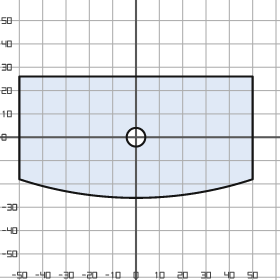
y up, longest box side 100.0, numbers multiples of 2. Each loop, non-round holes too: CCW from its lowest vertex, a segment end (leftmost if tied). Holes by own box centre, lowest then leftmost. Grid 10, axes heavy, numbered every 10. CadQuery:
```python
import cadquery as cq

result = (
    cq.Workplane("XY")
    .moveTo(-50.0, -18.0)
    .threePointArc((0.0, -26.0), (50.0, -18.0))
    .lineTo(50.0, 26.0)
    .lineTo(-50.0, 26.0)
    .close()
    .moveTo(0.0, 0.0)
    .circle(4.0)
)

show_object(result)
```